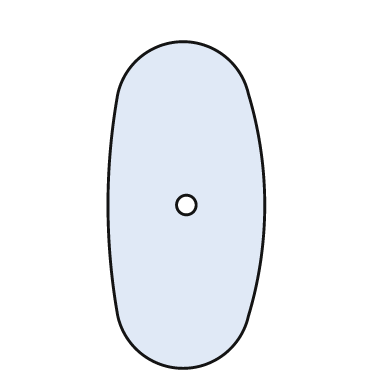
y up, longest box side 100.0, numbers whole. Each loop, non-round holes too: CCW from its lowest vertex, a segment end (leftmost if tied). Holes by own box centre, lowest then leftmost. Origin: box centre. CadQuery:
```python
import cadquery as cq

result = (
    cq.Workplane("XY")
    .moveTo(-21.0, -34.0)
    .threePointArc((-1.0, -50.0), (19.0, -34.0))
    .threePointArc((24.0, 0.0), (19.0, 34.0))
    .threePointArc((-1.0, 50.0), (-21.0, 34.0))
    .threePointArc((-24.0, 0.0), (-21.0, -34.0))
    .close()
    .moveTo(0.0, 0.0)
    .circle(3.0)
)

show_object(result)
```